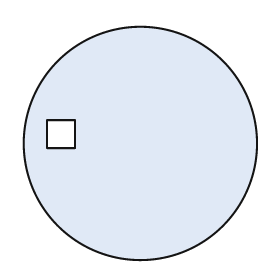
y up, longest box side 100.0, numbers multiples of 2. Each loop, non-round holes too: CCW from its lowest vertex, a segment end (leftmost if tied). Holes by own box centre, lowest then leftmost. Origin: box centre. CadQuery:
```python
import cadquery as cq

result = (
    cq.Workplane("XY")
    .moveTo(0.0, 0.0)
    .circle(50.0)
    .moveTo(-40.0, -2.0)
    .lineTo(-28.0, -2.0)
    .lineTo(-28.0, 10.0)
    .lineTo(-40.0, 10.0)
    .close()
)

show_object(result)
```